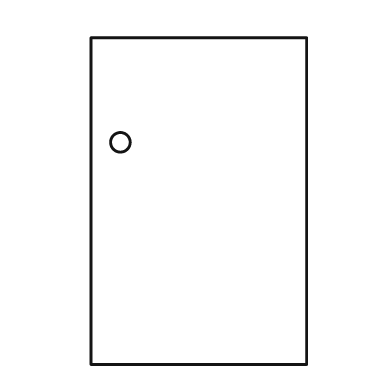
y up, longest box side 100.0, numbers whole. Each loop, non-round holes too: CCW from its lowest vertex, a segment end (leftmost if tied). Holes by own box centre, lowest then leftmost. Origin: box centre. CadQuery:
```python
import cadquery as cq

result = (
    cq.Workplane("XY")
    .moveTo(-33.0, -50.0)
    .lineTo(33.0, -50.0)
    .lineTo(33.0, 50.0)
    .lineTo(-33.0, 50.0)
    .close()
    .moveTo(-24.0, 18.0)
    .circle(3.0)
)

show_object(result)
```